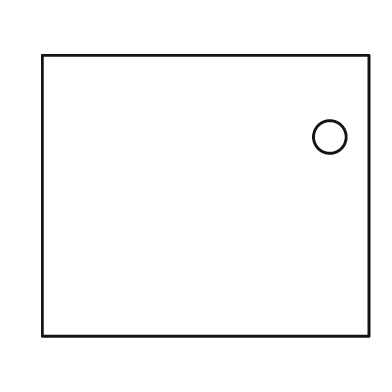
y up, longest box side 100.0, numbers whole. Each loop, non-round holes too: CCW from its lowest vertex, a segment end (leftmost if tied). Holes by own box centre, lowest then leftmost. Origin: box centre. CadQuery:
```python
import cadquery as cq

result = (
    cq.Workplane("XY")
    .moveTo(-50.0, -43.0)
    .lineTo(50.0, -43.0)
    .lineTo(50.0, 43.0)
    .lineTo(-50.0, 43.0)
    .close()
    .moveTo(38.0, 18.0)
    .circle(5.0)
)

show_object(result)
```